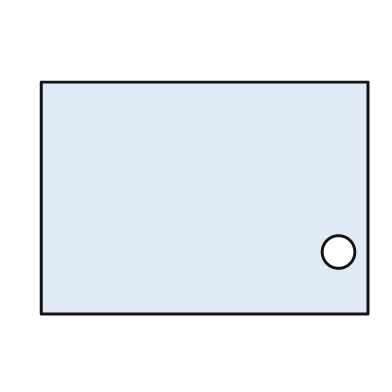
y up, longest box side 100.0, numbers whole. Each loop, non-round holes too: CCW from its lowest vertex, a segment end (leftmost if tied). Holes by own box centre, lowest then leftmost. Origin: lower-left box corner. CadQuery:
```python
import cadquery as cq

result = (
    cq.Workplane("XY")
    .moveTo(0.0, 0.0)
    .lineTo(100.0, 0.0)
    .lineTo(100.0, 71.0)
    .lineTo(0.0, 71.0)
    .close()
    .moveTo(91.0, 19.0)
    .circle(5.0)
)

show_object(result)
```